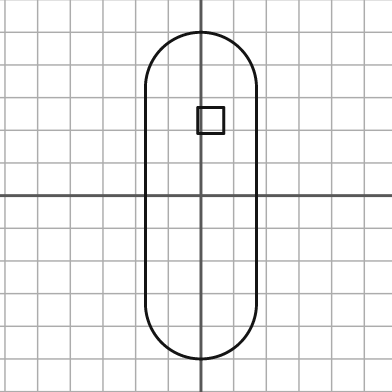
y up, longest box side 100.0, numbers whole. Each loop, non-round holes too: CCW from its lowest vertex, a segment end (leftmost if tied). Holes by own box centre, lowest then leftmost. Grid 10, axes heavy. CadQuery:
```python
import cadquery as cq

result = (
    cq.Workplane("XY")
    .moveTo(-17.0, -33.0)
    .threePointArc((0.0, -50.0), (17.0, -33.0))
    .lineTo(17.0, 33.0)
    .threePointArc((0.0, 50.0), (-17.0, 33.0))
    .close()
    .moveTo(-1.0, 19.0)
    .lineTo(7.0, 19.0)
    .lineTo(7.0, 27.0)
    .lineTo(-1.0, 27.0)
    .close()
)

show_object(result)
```